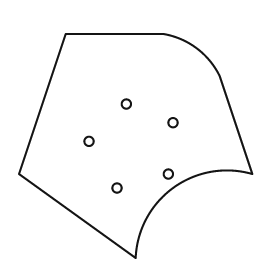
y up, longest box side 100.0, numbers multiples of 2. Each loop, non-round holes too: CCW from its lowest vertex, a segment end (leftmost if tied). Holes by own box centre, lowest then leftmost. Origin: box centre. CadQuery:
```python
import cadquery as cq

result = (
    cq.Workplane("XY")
    .moveTo(0.0, -48.0)
    .threePointArc((16.0, -18.0), (50.0, -12.0))
    .lineTo(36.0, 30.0)
    .threePointArc((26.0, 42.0), (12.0, 48.0))
    .lineTo(-30.0, 48.0)
    .lineTo(-50.0, -12.0)
    .close()
    .moveTo(-8.0, -18.0)
    .circle(2.0)
    .moveTo(14.0, -12.0)
    .circle(2.0)
    .moveTo(-20.0, 2.0)
    .circle(2.0)
    .moveTo(16.0, 10.0)
    .circle(2.0)
    .moveTo(-4.0, 18.0)
    .circle(2.0)
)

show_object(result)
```